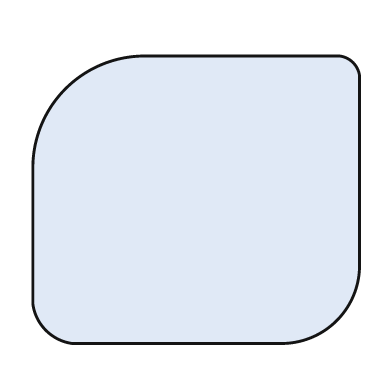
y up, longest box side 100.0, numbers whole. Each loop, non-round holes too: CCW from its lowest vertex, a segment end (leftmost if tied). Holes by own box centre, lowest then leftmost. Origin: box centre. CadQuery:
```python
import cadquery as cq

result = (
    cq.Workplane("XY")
    .moveTo(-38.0, -44.0)
    .lineTo(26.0, -44.0)
    .threePointArc((43.0, -37.0), (50.0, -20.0))
    .lineTo(50.0, 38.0)
    .threePointArc((48.0, 42.0), (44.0, 44.0))
    .lineTo(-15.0, 44.0)
    .threePointArc((-40.0, 34.0), (-50.0, 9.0))
    .lineTo(-50.0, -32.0)
    .threePointArc((-46.0, -40.0), (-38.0, -44.0))
    .close()
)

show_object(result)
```